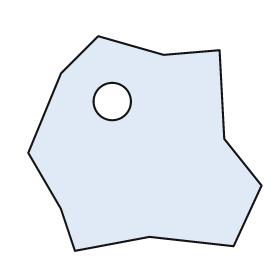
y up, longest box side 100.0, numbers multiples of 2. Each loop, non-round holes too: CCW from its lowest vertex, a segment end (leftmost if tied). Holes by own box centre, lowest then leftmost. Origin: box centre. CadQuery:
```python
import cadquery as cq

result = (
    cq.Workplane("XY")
    .moveTo(-30.0, -46.0)
    .lineTo(2.0, -40.0)
    .lineTo(38.0, -44.0)
    .lineTo(50.0, -18.0)
    .lineTo(34.0, 2.0)
    .lineTo(32.0, 40.0)
    .lineTo(8.0, 38.0)
    .lineTo(-20.0, 46.0)
    .lineTo(-36.0, 30.0)
    .lineTo(-50.0, -4.0)
    .lineTo(-36.0, -28.0)
    .close()
    .moveTo(-14.0, 18.0)
    .circle(8.0)
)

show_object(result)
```